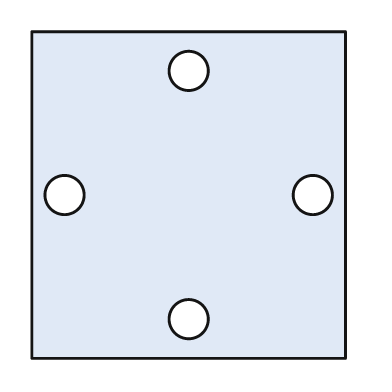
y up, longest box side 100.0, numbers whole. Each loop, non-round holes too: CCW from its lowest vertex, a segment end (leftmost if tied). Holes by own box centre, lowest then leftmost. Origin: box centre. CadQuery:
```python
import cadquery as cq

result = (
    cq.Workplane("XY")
    .moveTo(-48.0, -50.0)
    .lineTo(48.0, -50.0)
    .lineTo(48.0, 50.0)
    .lineTo(-48.0, 50.0)
    .close()
    .moveTo(0.0, -38.0)
    .circle(6.0)
    .moveTo(-38.0, 0.0)
    .circle(6.0)
    .moveTo(38.0, 0.0)
    .circle(6.0)
    .moveTo(0.0, 38.0)
    .circle(6.0)
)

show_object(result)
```